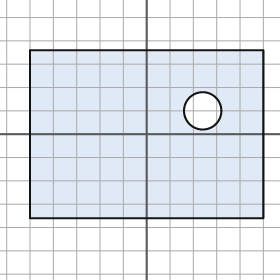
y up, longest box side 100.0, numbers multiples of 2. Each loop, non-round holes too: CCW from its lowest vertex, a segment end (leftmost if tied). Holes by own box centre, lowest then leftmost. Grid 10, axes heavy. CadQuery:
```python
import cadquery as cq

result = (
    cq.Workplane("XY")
    .moveTo(-50.0, -36.0)
    .lineTo(50.0, -36.0)
    .lineTo(50.0, 36.0)
    .lineTo(-50.0, 36.0)
    .close()
    .moveTo(24.0, 10.0)
    .circle(8.0)
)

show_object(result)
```